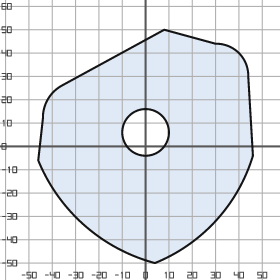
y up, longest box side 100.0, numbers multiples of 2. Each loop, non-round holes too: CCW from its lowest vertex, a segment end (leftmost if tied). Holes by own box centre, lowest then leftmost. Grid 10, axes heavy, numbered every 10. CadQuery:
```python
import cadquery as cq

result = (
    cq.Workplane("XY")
    .moveTo(4.0, -50.0)
    .threePointArc((30.0, -32.0), (46.0, -4.0))
    .lineTo(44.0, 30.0)
    .threePointArc((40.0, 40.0), (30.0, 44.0))
    .lineTo(8.0, 50.0)
    .lineTo(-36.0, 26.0)
    .threePointArc((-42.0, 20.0), (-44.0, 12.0))
    .lineTo(-46.0, -6.0)
    .threePointArc((-26.0, -34.0), (4.0, -50.0))
    .close()
    .moveTo(0.0, 6.0)
    .circle(10.0)
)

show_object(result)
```